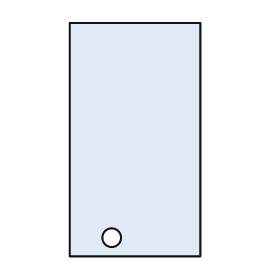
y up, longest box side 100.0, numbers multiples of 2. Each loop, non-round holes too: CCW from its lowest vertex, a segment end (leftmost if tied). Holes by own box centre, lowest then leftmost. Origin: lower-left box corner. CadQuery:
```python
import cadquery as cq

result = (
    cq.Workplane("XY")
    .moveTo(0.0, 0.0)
    .lineTo(56.0, 0.0)
    .lineTo(56.0, 100.0)
    .lineTo(0.0, 100.0)
    .close()
    .moveTo(18.0, 8.0)
    .circle(4.0)
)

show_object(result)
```